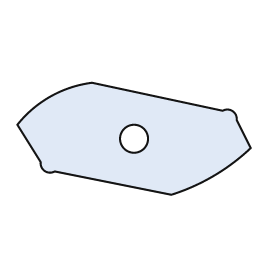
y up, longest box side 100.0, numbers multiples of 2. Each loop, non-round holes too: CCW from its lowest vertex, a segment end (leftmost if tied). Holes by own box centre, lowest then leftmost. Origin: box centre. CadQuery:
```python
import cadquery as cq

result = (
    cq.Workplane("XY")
    .moveTo(16.0, -24.0)
    .threePointArc((34.0, -16.0), (50.0, -4.0))
    .lineTo(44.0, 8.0)
    .threePointArc((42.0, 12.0), (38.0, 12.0))
    .lineTo(-18.0, 24.0)
    .threePointArc((-36.0, 18.0), (-50.0, 6.0))
    .lineTo(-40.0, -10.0)
    .threePointArc((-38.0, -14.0), (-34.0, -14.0))
    .close()
    .moveTo(0.0, 0.0)
    .circle(6.0)
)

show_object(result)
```